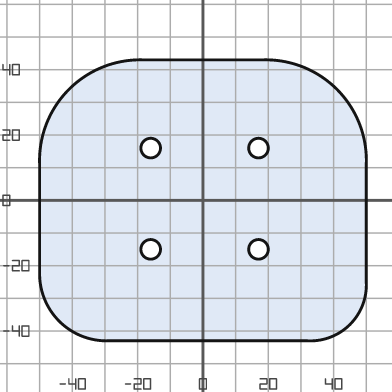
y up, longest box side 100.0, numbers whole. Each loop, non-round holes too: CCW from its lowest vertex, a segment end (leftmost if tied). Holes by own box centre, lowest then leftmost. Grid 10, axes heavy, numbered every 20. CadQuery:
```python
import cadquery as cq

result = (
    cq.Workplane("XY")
    .moveTo(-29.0, -43.0)
    .lineTo(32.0, -43.0)
    .threePointArc((45.0, -38.0), (50.0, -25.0))
    .lineTo(50.0, 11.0)
    .threePointArc((41.0, 34.0), (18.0, 43.0))
    .lineTo(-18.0, 43.0)
    .threePointArc((-41.0, 34.0), (-50.0, 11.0))
    .lineTo(-50.0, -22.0)
    .threePointArc((-44.0, -37.0), (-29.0, -43.0))
    .close()
    .moveTo(-16.0, -15.0)
    .circle(3.0)
    .moveTo(17.0, -15.0)
    .circle(3.0)
    .moveTo(-16.0, 16.0)
    .circle(3.0)
    .moveTo(17.0, 16.0)
    .circle(3.0)
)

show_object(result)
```